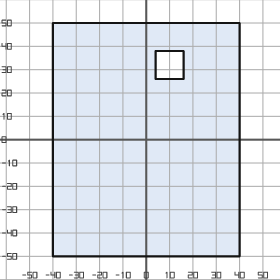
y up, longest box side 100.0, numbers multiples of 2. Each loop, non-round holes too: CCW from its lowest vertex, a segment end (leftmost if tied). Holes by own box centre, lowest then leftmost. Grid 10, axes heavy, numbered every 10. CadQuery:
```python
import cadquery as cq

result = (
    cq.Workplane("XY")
    .moveTo(-40.0, -50.0)
    .lineTo(40.0, -50.0)
    .lineTo(40.0, 50.0)
    .lineTo(-40.0, 50.0)
    .close()
    .moveTo(4.0, 26.0)
    .lineTo(16.0, 26.0)
    .lineTo(16.0, 38.0)
    .lineTo(4.0, 38.0)
    .close()
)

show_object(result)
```